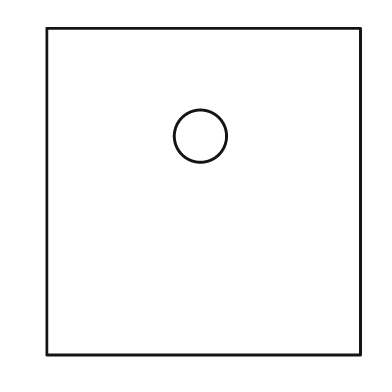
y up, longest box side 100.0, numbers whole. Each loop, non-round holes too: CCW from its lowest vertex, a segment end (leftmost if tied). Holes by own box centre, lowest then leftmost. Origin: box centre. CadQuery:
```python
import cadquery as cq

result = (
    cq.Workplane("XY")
    .moveTo(-48.0, -50.0)
    .lineTo(48.0, -50.0)
    .lineTo(48.0, 50.0)
    .lineTo(-48.0, 50.0)
    .close()
    .moveTo(-1.0, 17.0)
    .circle(8.0)
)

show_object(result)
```